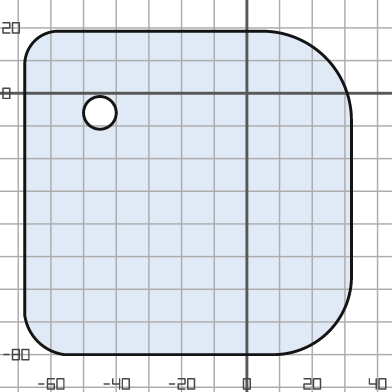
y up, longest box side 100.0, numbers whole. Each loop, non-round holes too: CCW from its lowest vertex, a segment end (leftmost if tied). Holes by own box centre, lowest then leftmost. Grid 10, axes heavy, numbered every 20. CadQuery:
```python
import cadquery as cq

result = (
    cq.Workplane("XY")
    .moveTo(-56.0, -80.0)
    .lineTo(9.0, -80.0)
    .threePointArc((25.0, -73.0), (32.0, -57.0))
    .lineTo(32.0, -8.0)
    .threePointArc((24.0, 11.0), (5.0, 19.0))
    .lineTo(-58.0, 19.0)
    .threePointArc((-65.0, 16.0), (-68.0, 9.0))
    .lineTo(-68.0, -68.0)
    .threePointArc((-64.0, -76.0), (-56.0, -80.0))
    .close()
    .moveTo(-45.0, -6.0)
    .circle(5.0)
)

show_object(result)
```